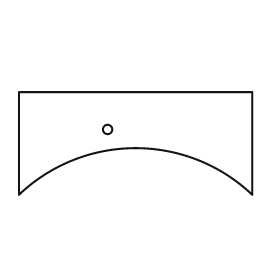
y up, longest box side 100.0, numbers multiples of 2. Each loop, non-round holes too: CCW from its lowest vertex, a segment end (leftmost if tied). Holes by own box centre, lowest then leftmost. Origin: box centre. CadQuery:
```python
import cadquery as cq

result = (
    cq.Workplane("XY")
    .moveTo(-50.0, -22.0)
    .threePointArc((0.0, -2.0), (50.0, -22.0))
    .lineTo(50.0, 22.0)
    .lineTo(-50.0, 22.0)
    .close()
    .moveTo(-12.0, 6.0)
    .circle(2.0)
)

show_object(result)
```